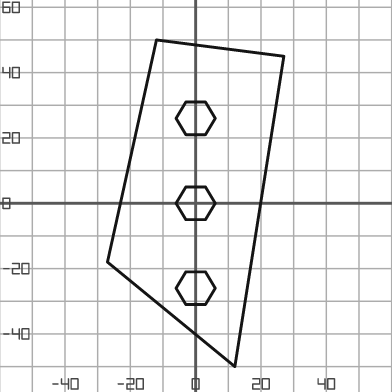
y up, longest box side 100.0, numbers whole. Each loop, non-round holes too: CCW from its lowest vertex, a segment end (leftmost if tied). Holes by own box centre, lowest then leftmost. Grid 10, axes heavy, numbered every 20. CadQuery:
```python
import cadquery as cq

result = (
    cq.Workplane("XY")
    .moveTo(12.0, -50.0)
    .lineTo(27.0, 45.0)
    .lineTo(-12.0, 50.0)
    .lineTo(-27.0, -18.0)
    .close()
    .moveTo(-3.0, -31.0)
    .lineTo(3.0, -31.0)
    .lineTo(6.0, -26.0)
    .lineTo(3.0, -21.0)
    .lineTo(-3.0, -21.0)
    .lineTo(-6.0, -26.0)
    .close()
    .moveTo(-3.0, -5.0)
    .lineTo(3.0, -5.0)
    .lineTo(6.0, 0.0)
    .lineTo(3.0, 5.0)
    .lineTo(-3.0, 5.0)
    .lineTo(-6.0, 0.0)
    .close()
    .moveTo(-3.0, 21.0)
    .lineTo(3.0, 21.0)
    .lineTo(6.0, 26.0)
    .lineTo(3.0, 31.0)
    .lineTo(-3.0, 31.0)
    .lineTo(-6.0, 26.0)
    .close()
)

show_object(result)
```